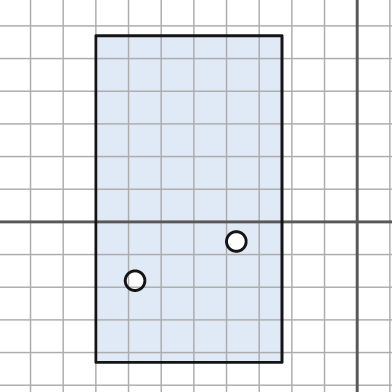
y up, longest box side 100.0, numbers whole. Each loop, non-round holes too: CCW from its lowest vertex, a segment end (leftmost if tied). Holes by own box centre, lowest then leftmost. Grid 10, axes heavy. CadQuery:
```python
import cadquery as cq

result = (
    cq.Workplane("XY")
    .moveTo(-80.0, -43.0)
    .lineTo(-23.0, -43.0)
    .lineTo(-23.0, 57.0)
    .lineTo(-80.0, 57.0)
    .close()
    .moveTo(-68.0, -18.0)
    .circle(3.0)
    .moveTo(-37.0, -6.0)
    .circle(3.0)
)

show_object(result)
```